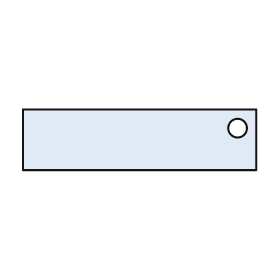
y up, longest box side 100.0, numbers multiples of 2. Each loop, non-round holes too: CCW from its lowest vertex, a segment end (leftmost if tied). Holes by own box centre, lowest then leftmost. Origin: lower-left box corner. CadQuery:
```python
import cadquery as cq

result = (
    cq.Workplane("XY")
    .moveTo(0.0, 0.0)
    .lineTo(100.0, 0.0)
    .lineTo(100.0, 26.0)
    .lineTo(0.0, 26.0)
    .close()
    .moveTo(92.0, 18.0)
    .circle(4.0)
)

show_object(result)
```